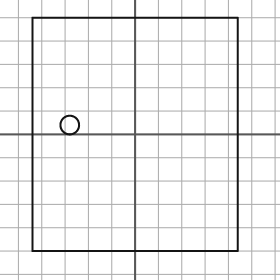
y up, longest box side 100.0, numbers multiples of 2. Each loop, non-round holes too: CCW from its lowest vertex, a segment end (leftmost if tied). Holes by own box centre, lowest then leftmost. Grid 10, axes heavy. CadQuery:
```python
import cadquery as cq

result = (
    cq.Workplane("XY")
    .moveTo(-44.0, -50.0)
    .lineTo(44.0, -50.0)
    .lineTo(44.0, 50.0)
    .lineTo(-44.0, 50.0)
    .close()
    .moveTo(-28.0, 4.0)
    .circle(4.0)
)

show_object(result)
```